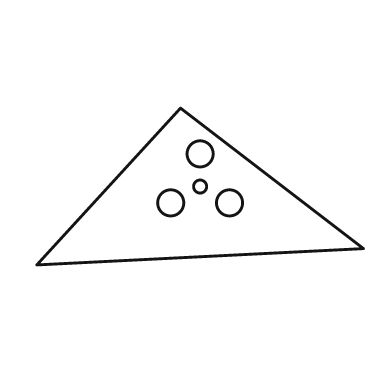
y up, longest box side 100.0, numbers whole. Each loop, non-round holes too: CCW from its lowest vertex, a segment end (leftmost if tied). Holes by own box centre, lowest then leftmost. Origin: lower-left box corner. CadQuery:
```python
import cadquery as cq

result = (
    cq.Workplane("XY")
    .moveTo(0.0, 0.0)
    .lineTo(100.0, 5.0)
    .lineTo(44.0, 48.0)
    .close()
    .moveTo(41.0, 19.0)
    .circle(4.0)
    .moveTo(59.0, 19.0)
    .circle(4.0)
    .moveTo(50.0, 24.0)
    .circle(2.0)
    .moveTo(50.0, 34.0)
    .circle(4.0)
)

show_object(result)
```